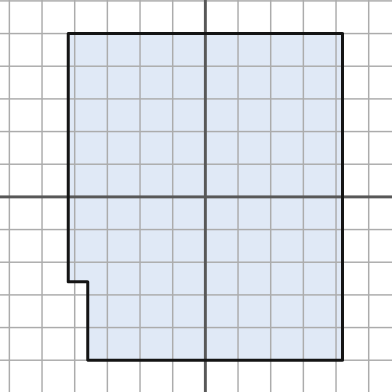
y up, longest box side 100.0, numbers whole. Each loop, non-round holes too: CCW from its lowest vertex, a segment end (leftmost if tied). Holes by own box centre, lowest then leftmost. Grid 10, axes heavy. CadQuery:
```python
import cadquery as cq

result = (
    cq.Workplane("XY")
    .moveTo(-36.0, -50.0)
    .lineTo(42.0, -50.0)
    .lineTo(42.0, 50.0)
    .lineTo(-42.0, 50.0)
    .lineTo(-42.0, -26.0)
    .lineTo(-36.0, -26.0)
    .close()
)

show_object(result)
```